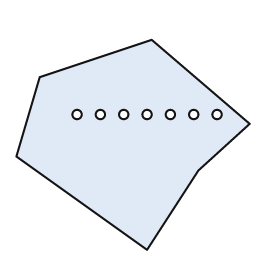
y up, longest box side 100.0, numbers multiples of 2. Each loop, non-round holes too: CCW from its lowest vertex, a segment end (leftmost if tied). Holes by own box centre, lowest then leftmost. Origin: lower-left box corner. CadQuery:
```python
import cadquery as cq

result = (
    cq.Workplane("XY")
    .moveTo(56.0, 0.0)
    .lineTo(78.0, 34.0)
    .lineTo(100.0, 54.0)
    .lineTo(58.0, 90.0)
    .lineTo(10.0, 74.0)
    .lineTo(0.0, 40.0)
    .close()
    .moveTo(26.0, 58.0)
    .circle(2.0)
    .moveTo(36.0, 58.0)
    .circle(2.0)
    .moveTo(46.0, 58.0)
    .circle(2.0)
    .moveTo(56.0, 58.0)
    .circle(2.0)
    .moveTo(66.0, 58.0)
    .circle(2.0)
    .moveTo(76.0, 58.0)
    .circle(2.0)
    .moveTo(86.0, 58.0)
    .circle(2.0)
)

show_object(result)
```